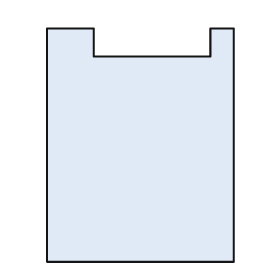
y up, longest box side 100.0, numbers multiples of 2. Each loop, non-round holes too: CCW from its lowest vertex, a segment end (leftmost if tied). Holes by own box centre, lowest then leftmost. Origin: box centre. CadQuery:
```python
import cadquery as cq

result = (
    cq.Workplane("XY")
    .moveTo(-40.0, -50.0)
    .lineTo(40.0, -50.0)
    .lineTo(40.0, 50.0)
    .lineTo(30.0, 50.0)
    .lineTo(30.0, 38.0)
    .lineTo(-20.0, 38.0)
    .lineTo(-20.0, 50.0)
    .lineTo(-40.0, 50.0)
    .close()
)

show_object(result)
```